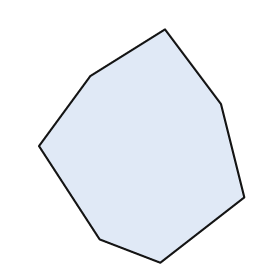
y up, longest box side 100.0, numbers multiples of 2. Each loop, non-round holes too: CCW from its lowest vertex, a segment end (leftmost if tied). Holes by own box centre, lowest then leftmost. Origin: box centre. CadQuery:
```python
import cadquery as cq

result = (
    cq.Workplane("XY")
    .moveTo(8.0, -50.0)
    .lineTo(44.0, -22.0)
    .lineTo(34.0, 18.0)
    .lineTo(10.0, 50.0)
    .lineTo(-22.0, 30.0)
    .lineTo(-44.0, 0.0)
    .lineTo(-18.0, -40.0)
    .close()
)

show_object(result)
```